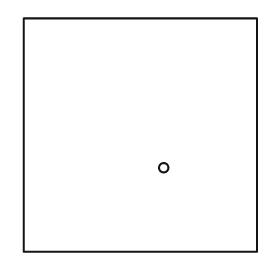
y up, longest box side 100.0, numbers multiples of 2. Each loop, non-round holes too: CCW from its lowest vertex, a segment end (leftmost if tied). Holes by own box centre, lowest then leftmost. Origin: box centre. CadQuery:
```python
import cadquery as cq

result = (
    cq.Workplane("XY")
    .moveTo(-50.0, -50.0)
    .lineTo(50.0, -50.0)
    .lineTo(50.0, 50.0)
    .lineTo(-50.0, 50.0)
    .close()
    .moveTo(10.0, -14.0)
    .circle(2.0)
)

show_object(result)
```